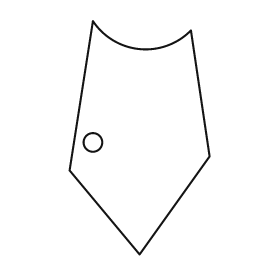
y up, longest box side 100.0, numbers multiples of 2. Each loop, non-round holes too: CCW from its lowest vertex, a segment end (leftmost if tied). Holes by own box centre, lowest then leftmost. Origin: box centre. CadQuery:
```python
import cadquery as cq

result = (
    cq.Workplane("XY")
    .moveTo(0.0, -50.0)
    .lineTo(30.0, -8.0)
    .lineTo(22.0, 46.0)
    .threePointArc((0.0, 38.0), (-20.0, 50.0))
    .lineTo(-30.0, -14.0)
    .close()
    .moveTo(-20.0, -2.0)
    .circle(4.0)
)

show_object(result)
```